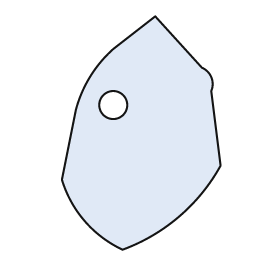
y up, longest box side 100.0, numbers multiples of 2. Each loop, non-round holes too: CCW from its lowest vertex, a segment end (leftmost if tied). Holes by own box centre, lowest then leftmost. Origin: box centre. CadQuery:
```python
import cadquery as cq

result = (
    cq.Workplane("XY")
    .moveTo(-8.0, -50.0)
    .threePointArc((16.0, -36.0), (34.0, -14.0))
    .lineTo(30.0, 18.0)
    .threePointArc((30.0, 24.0), (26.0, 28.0))
    .lineTo(6.0, 50.0)
    .lineTo(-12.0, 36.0)
    .threePointArc((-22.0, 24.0), (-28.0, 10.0))
    .lineTo(-34.0, -20.0)
    .threePointArc((-24.0, -38.0), (-8.0, -50.0))
    .close()
    .moveTo(-12.0, 12.0)
    .circle(6.0)
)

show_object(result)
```